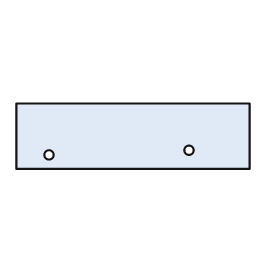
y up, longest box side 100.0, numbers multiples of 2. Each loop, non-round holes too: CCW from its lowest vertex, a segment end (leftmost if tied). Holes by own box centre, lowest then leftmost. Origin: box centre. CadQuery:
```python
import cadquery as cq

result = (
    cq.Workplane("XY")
    .moveTo(-50.0, -14.0)
    .lineTo(50.0, -14.0)
    .lineTo(50.0, 14.0)
    .lineTo(-50.0, 14.0)
    .close()
    .moveTo(-36.0, -8.0)
    .circle(2.0)
    .moveTo(24.0, -6.0)
    .circle(2.0)
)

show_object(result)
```